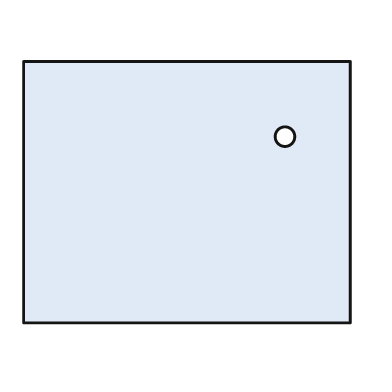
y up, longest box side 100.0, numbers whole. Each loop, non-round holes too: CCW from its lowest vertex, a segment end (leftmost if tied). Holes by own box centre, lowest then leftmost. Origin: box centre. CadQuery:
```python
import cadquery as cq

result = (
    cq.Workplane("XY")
    .moveTo(-50.0, -40.0)
    .lineTo(50.0, -40.0)
    .lineTo(50.0, 40.0)
    .lineTo(-50.0, 40.0)
    .close()
    .moveTo(30.0, 17.0)
    .circle(3.0)
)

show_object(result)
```